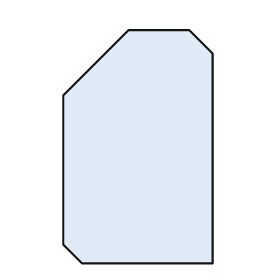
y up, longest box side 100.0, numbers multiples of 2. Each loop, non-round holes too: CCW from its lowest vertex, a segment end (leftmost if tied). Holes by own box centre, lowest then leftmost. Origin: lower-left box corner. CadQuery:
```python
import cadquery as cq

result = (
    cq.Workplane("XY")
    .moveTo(8.0, 0.0)
    .lineTo(64.0, 0.0)
    .lineTo(64.0, 90.0)
    .lineTo(54.0, 100.0)
    .lineTo(28.0, 100.0)
    .lineTo(0.0, 72.0)
    .lineTo(0.0, 8.0)
    .close()
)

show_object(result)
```